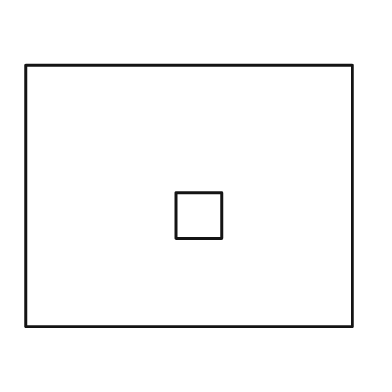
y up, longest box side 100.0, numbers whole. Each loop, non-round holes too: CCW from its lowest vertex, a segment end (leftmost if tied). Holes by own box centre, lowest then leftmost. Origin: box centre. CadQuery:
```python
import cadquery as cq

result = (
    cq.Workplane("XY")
    .moveTo(-50.0, -40.0)
    .lineTo(50.0, -40.0)
    .lineTo(50.0, 40.0)
    .lineTo(-50.0, 40.0)
    .close()
    .moveTo(-4.0, -13.0)
    .lineTo(10.0, -13.0)
    .lineTo(10.0, 1.0)
    .lineTo(-4.0, 1.0)
    .close()
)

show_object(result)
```